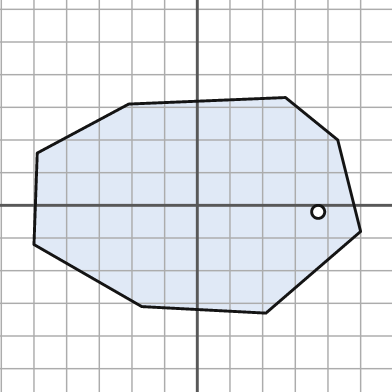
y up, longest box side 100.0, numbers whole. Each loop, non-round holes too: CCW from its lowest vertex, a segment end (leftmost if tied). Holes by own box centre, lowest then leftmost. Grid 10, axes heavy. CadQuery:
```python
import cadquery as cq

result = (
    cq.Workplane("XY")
    .moveTo(21.0, -33.0)
    .lineTo(50.0, -8.0)
    .lineTo(43.0, 20.0)
    .lineTo(27.0, 33.0)
    .lineTo(-21.0, 31.0)
    .lineTo(-49.0, 16.0)
    .lineTo(-50.0, -12.0)
    .lineTo(-17.0, -31.0)
    .close()
    .moveTo(37.0, -2.0)
    .circle(2.0)
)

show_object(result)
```